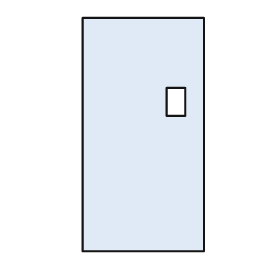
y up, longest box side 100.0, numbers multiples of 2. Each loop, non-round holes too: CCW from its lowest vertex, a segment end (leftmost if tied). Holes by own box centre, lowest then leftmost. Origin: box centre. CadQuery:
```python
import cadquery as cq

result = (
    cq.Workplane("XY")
    .moveTo(-26.0, -50.0)
    .lineTo(26.0, -50.0)
    .lineTo(26.0, 50.0)
    .lineTo(-26.0, 50.0)
    .close()
    .moveTo(10.0, 8.0)
    .lineTo(18.0, 8.0)
    .lineTo(18.0, 20.0)
    .lineTo(10.0, 20.0)
    .close()
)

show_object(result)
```